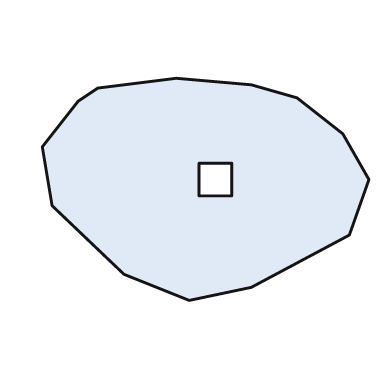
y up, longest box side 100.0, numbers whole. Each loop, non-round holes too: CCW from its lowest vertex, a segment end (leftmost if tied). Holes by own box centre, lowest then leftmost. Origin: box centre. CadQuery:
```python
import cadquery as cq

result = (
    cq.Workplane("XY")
    .moveTo(-5.0, -34.0)
    .lineTo(14.0, -30.0)
    .lineTo(44.0, -14.0)
    .lineTo(50.0, 3.0)
    .lineTo(42.0, 17.0)
    .lineTo(28.0, 28.0)
    .lineTo(14.0, 32.0)
    .lineTo(-9.0, 34.0)
    .lineTo(-33.0, 31.0)
    .lineTo(-39.0, 27.0)
    .lineTo(-50.0, 13.0)
    .lineTo(-47.0, -5.0)
    .lineTo(-25.0, -26.0)
    .close()
    .moveTo(-2.0, -2.0)
    .lineTo(8.0, -2.0)
    .lineTo(8.0, 8.0)
    .lineTo(-2.0, 8.0)
    .close()
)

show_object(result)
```